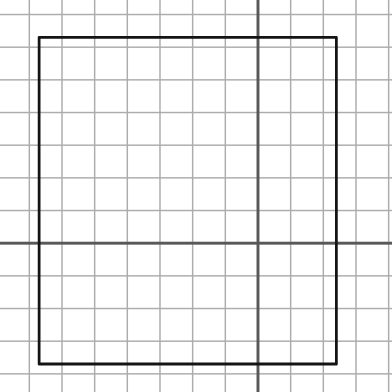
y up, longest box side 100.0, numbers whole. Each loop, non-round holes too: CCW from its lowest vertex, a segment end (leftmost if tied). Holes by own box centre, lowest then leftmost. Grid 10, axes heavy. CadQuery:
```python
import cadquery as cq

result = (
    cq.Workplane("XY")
    .moveTo(-67.0, -37.0)
    .lineTo(24.0, -37.0)
    .lineTo(24.0, 63.0)
    .lineTo(-67.0, 63.0)
    .close()
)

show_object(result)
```